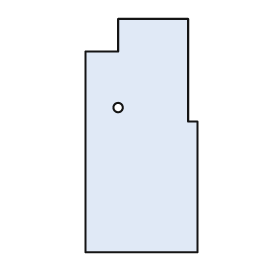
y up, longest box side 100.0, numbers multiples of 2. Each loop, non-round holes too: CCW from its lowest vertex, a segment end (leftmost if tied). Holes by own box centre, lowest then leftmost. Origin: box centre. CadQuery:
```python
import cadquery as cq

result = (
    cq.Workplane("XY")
    .moveTo(-24.0, -50.0)
    .lineTo(24.0, -50.0)
    .lineTo(24.0, 6.0)
    .lineTo(20.0, 6.0)
    .lineTo(20.0, 50.0)
    .lineTo(-10.0, 50.0)
    .lineTo(-10.0, 36.0)
    .lineTo(-24.0, 36.0)
    .close()
    .moveTo(-10.0, 12.0)
    .circle(2.0)
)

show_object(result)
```